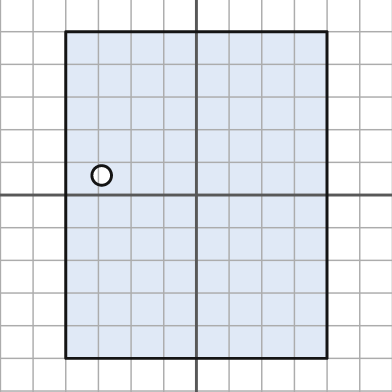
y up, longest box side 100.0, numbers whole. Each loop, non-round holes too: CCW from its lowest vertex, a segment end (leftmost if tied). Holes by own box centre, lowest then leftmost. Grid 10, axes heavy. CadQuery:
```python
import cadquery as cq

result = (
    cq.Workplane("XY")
    .moveTo(-40.0, -50.0)
    .lineTo(40.0, -50.0)
    .lineTo(40.0, 50.0)
    .lineTo(-40.0, 50.0)
    .close()
    .moveTo(-29.0, 6.0)
    .circle(3.0)
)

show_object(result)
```